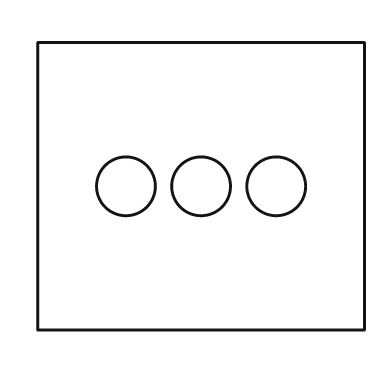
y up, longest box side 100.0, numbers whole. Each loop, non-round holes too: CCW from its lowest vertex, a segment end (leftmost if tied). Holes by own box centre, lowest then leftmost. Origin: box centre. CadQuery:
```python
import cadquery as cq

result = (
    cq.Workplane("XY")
    .moveTo(-50.0, -44.0)
    .lineTo(50.0, -44.0)
    .lineTo(50.0, 44.0)
    .lineTo(-50.0, 44.0)
    .close()
    .moveTo(-23.0, 0.0)
    .circle(9.0)
    .moveTo(0.0, 0.0)
    .circle(9.0)
    .moveTo(23.0, 0.0)
    .circle(9.0)
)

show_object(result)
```